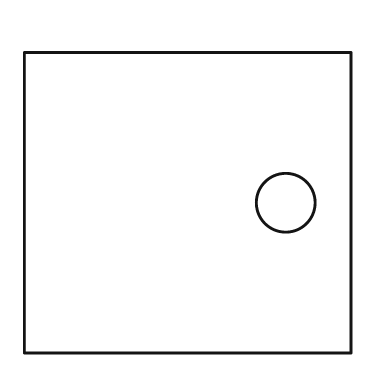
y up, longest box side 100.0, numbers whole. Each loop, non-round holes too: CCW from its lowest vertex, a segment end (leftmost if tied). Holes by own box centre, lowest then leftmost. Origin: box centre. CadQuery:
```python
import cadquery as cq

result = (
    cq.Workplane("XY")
    .moveTo(-50.0, -46.0)
    .lineTo(50.0, -46.0)
    .lineTo(50.0, 46.0)
    .lineTo(-50.0, 46.0)
    .close()
    .moveTo(30.0, 0.0)
    .circle(9.0)
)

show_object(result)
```